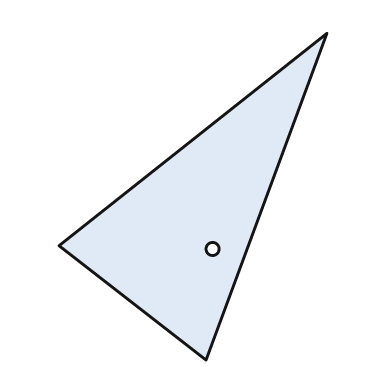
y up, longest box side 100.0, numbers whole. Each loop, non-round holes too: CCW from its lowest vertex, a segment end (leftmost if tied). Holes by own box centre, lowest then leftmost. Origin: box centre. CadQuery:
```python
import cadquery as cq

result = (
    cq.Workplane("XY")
    .moveTo(4.0, -50.0)
    .lineTo(41.0, 50.0)
    .lineTo(-41.0, -15.0)
    .close()
    .moveTo(6.0, -16.0)
    .circle(2.0)
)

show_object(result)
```